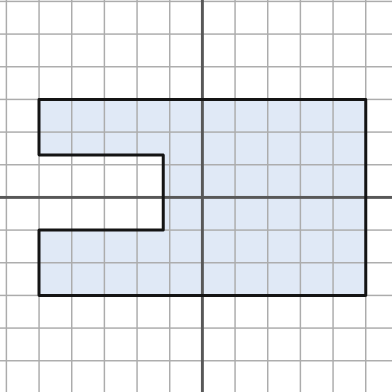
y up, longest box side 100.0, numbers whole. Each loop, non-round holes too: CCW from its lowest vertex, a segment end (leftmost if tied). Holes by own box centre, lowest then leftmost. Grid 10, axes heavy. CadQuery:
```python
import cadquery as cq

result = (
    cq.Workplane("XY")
    .moveTo(-50.0, -30.0)
    .lineTo(50.0, -30.0)
    .lineTo(50.0, 30.0)
    .lineTo(-50.0, 30.0)
    .lineTo(-50.0, 13.0)
    .lineTo(-12.0, 13.0)
    .lineTo(-12.0, -10.0)
    .lineTo(-50.0, -10.0)
    .close()
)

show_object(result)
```